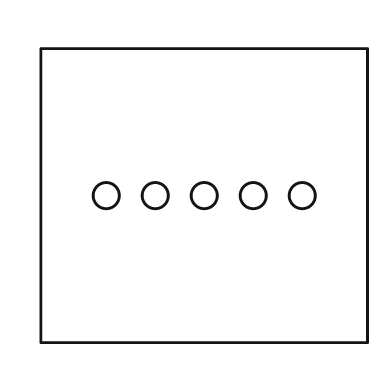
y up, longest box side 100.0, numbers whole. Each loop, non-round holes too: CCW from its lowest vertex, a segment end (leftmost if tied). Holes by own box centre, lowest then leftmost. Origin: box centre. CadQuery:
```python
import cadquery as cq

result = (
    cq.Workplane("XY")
    .moveTo(-50.0, -45.0)
    .lineTo(50.0, -45.0)
    .lineTo(50.0, 45.0)
    .lineTo(-50.0, 45.0)
    .close()
    .moveTo(-30.0, 0.0)
    .circle(4.0)
    .moveTo(-15.0, 0.0)
    .circle(4.0)
    .moveTo(0.0, 0.0)
    .circle(4.0)
    .moveTo(15.0, 0.0)
    .circle(4.0)
    .moveTo(30.0, 0.0)
    .circle(4.0)
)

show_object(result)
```